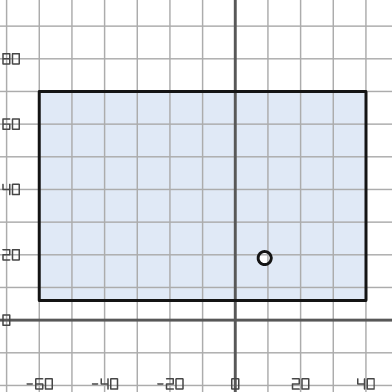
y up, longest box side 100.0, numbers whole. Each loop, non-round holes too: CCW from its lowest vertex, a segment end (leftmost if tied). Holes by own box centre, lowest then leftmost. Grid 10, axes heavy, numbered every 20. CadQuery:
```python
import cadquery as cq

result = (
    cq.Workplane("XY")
    .moveTo(-60.0, 6.0)
    .lineTo(40.0, 6.0)
    .lineTo(40.0, 70.0)
    .lineTo(-60.0, 70.0)
    .close()
    .moveTo(9.0, 19.0)
    .circle(2.0)
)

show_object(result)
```